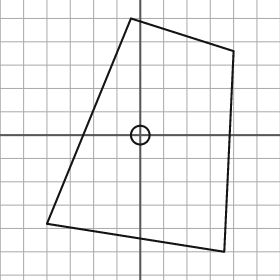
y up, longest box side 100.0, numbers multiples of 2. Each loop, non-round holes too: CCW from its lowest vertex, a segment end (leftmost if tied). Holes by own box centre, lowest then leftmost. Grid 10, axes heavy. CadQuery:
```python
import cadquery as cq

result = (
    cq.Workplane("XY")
    .moveTo(36.0, -50.0)
    .lineTo(40.0, 36.0)
    .lineTo(-4.0, 50.0)
    .lineTo(-40.0, -38.0)
    .close()
    .moveTo(0.0, 0.0)
    .circle(4.0)
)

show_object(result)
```